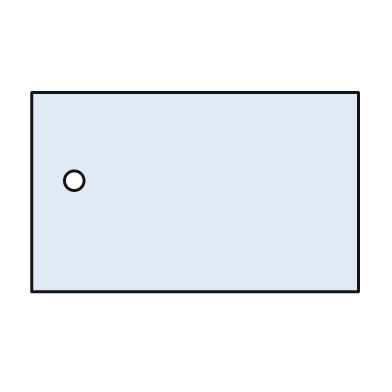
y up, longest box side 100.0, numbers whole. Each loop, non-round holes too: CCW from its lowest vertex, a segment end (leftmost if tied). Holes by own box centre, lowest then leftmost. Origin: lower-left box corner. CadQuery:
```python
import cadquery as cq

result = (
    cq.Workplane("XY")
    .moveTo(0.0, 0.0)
    .lineTo(100.0, 0.0)
    .lineTo(100.0, 61.0)
    .lineTo(0.0, 61.0)
    .close()
    .moveTo(13.0, 34.0)
    .circle(3.0)
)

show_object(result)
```